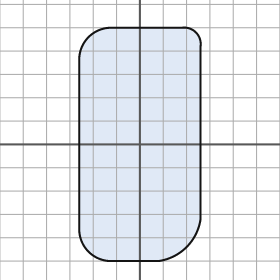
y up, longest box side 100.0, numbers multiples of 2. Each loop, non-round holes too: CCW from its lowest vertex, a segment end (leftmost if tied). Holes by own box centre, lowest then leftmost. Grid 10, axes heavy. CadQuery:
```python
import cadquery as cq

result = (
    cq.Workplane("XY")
    .moveTo(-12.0, -50.0)
    .lineTo(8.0, -50.0)
    .threePointArc((20.0, -44.0), (26.0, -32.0))
    .lineTo(26.0, 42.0)
    .threePointArc((24.0, 48.0), (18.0, 50.0))
    .lineTo(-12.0, 50.0)
    .threePointArc((-22.0, 46.0), (-26.0, 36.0))
    .lineTo(-26.0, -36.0)
    .threePointArc((-22.0, -46.0), (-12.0, -50.0))
    .close()
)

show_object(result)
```